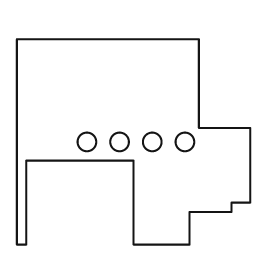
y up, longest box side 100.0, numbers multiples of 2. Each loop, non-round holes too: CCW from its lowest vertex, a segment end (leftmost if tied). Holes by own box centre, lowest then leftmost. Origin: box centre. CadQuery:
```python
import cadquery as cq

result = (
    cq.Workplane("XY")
    .moveTo(-50.0, -44.0)
    .lineTo(-46.0, -44.0)
    .lineTo(-46.0, -8.0)
    .lineTo(0.0, -8.0)
    .lineTo(0.0, -44.0)
    .lineTo(24.0, -44.0)
    .lineTo(24.0, -30.0)
    .lineTo(42.0, -30.0)
    .lineTo(42.0, -26.0)
    .lineTo(50.0, -26.0)
    .lineTo(50.0, 6.0)
    .lineTo(28.0, 6.0)
    .lineTo(28.0, 44.0)
    .lineTo(-50.0, 44.0)
    .close()
    .moveTo(-20.0, 0.0)
    .circle(4.0)
    .moveTo(-6.0, 0.0)
    .circle(4.0)
    .moveTo(8.0, 0.0)
    .circle(4.0)
    .moveTo(22.0, 0.0)
    .circle(4.0)
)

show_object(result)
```